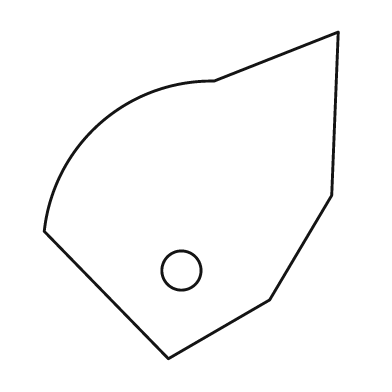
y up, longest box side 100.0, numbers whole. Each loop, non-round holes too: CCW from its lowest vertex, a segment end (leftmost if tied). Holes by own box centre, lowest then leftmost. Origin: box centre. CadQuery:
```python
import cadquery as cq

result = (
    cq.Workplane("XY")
    .moveTo(-7.0, -50.0)
    .lineTo(24.0, -32.0)
    .lineTo(43.0, 0.0)
    .lineTo(45.0, 50.0)
    .lineTo(7.0, 35.0)
    .threePointArc((-28.0, 22.0), (-45.0, -11.0))
    .close()
    .moveTo(-3.0, -23.0)
    .circle(6.0)
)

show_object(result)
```